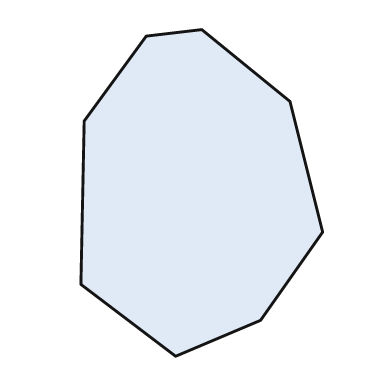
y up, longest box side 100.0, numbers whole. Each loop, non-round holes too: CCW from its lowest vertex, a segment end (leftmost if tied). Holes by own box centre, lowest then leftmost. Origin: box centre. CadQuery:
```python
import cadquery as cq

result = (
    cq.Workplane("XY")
    .moveTo(-8.0, -50.0)
    .lineTo(18.0, -39.0)
    .lineTo(37.0, -12.0)
    .lineTo(27.0, 28.0)
    .lineTo(0.0, 50.0)
    .lineTo(-17.0, 48.0)
    .lineTo(-36.0, 22.0)
    .lineTo(-37.0, -28.0)
    .close()
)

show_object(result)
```